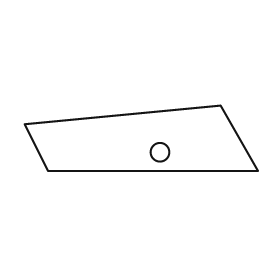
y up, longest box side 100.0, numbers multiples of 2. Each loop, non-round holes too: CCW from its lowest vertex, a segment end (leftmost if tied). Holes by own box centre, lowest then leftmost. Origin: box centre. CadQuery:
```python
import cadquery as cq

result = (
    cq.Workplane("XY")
    .moveTo(-40.0, -14.0)
    .lineTo(50.0, -14.0)
    .lineTo(34.0, 14.0)
    .lineTo(-50.0, 6.0)
    .close()
    .moveTo(8.0, -6.0)
    .circle(4.0)
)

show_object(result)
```